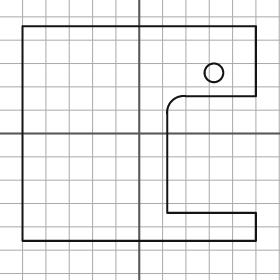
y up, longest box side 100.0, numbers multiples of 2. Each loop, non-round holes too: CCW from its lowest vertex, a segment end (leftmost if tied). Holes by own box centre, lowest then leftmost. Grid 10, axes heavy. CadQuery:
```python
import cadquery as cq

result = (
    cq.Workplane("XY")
    .moveTo(-50.0, -46.0)
    .lineTo(50.0, -46.0)
    .lineTo(50.0, -34.0)
    .lineTo(12.0, -34.0)
    .lineTo(12.0, 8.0)
    .threePointArc((14.0, 14.0), (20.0, 16.0))
    .lineTo(50.0, 16.0)
    .lineTo(50.0, 46.0)
    .lineTo(-50.0, 46.0)
    .close()
    .moveTo(32.0, 26.0)
    .circle(4.0)
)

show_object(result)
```